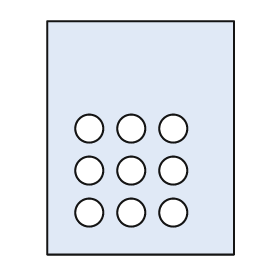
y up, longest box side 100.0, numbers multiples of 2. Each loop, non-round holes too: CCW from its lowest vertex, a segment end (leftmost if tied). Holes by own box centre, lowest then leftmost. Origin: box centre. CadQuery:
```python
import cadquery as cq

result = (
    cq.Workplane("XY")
    .moveTo(-40.0, -50.0)
    .lineTo(40.0, -50.0)
    .lineTo(40.0, 50.0)
    .lineTo(-40.0, 50.0)
    .close()
    .moveTo(-22.0, -32.0)
    .circle(6.0)
    .moveTo(-4.0, -32.0)
    .circle(6.0)
    .moveTo(14.0, -32.0)
    .circle(6.0)
    .moveTo(-22.0, -14.0)
    .circle(6.0)
    .moveTo(-4.0, -14.0)
    .circle(6.0)
    .moveTo(14.0, -14.0)
    .circle(6.0)
    .moveTo(-22.0, 4.0)
    .circle(6.0)
    .moveTo(-4.0, 4.0)
    .circle(6.0)
    .moveTo(14.0, 4.0)
    .circle(6.0)
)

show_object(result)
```